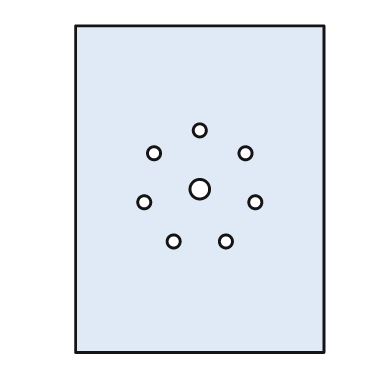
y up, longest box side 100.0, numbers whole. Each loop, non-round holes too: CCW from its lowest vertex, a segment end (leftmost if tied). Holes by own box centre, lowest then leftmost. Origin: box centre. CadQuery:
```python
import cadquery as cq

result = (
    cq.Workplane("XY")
    .moveTo(-38.0, -50.0)
    .lineTo(38.0, -50.0)
    .lineTo(38.0, 50.0)
    .lineTo(-38.0, 50.0)
    .close()
    .moveTo(-8.0, -16.0)
    .circle(2.0)
    .moveTo(8.0, -16.0)
    .circle(2.0)
    .moveTo(-17.0, -4.0)
    .circle(2.0)
    .moveTo(17.0, -4.0)
    .circle(2.0)
    .moveTo(0.0, 0.0)
    .circle(3.0)
    .moveTo(-14.0, 11.0)
    .circle(2.0)
    .moveTo(14.0, 11.0)
    .circle(2.0)
    .moveTo(0.0, 18.0)
    .circle(2.0)
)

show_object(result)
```